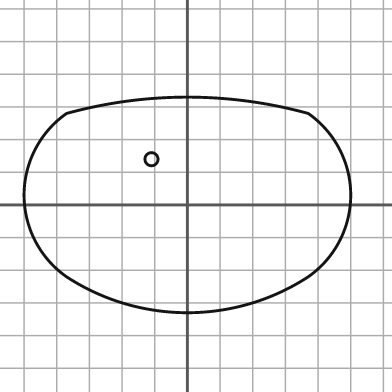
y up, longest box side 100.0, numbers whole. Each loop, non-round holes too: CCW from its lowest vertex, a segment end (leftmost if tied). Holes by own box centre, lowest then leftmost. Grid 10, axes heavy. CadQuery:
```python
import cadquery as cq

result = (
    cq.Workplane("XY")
    .moveTo(-37.0, -22.0)
    .threePointArc((0.0, -33.0), (37.0, -22.0))
    .threePointArc((50.0, 3.0), (37.0, 28.0))
    .threePointArc((0.0, 33.0), (-37.0, 28.0))
    .threePointArc((-50.0, 3.0), (-37.0, -22.0))
    .close()
    .moveTo(-11.0, 14.0)
    .circle(2.0)
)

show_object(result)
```